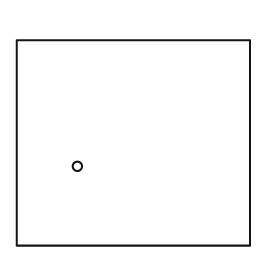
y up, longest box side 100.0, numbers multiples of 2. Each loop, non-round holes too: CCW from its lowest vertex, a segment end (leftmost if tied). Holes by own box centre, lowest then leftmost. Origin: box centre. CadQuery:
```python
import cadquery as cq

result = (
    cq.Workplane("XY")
    .moveTo(-50.0, -44.0)
    .lineTo(50.0, -44.0)
    .lineTo(50.0, 44.0)
    .lineTo(-50.0, 44.0)
    .close()
    .moveTo(-24.0, -10.0)
    .circle(2.0)
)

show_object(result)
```